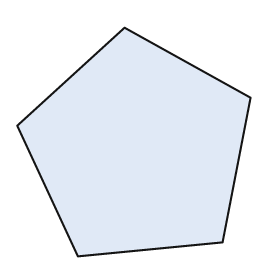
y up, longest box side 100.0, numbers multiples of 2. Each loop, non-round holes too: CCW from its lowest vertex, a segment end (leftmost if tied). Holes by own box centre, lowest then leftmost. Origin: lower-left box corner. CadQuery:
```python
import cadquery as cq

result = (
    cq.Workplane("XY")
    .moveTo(26.0, 0.0)
    .lineTo(88.0, 6.0)
    .lineTo(100.0, 68.0)
    .lineTo(46.0, 98.0)
    .lineTo(0.0, 56.0)
    .close()
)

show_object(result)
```